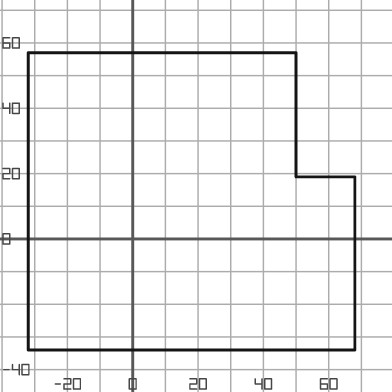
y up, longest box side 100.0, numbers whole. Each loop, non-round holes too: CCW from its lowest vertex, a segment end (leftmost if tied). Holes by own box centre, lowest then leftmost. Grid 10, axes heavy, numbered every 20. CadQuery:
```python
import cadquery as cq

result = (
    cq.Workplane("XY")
    .moveTo(-32.0, -34.0)
    .lineTo(68.0, -34.0)
    .lineTo(68.0, 19.0)
    .lineTo(50.0, 19.0)
    .lineTo(50.0, 57.0)
    .lineTo(-32.0, 57.0)
    .close()
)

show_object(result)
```